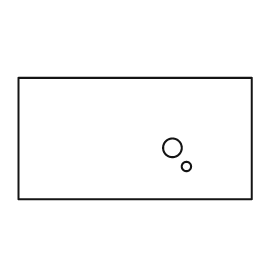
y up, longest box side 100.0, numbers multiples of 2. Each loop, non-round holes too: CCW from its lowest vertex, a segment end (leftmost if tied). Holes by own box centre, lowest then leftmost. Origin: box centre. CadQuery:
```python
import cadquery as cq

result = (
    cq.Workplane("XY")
    .moveTo(-50.0, -26.0)
    .lineTo(50.0, -26.0)
    .lineTo(50.0, 26.0)
    .lineTo(-50.0, 26.0)
    .close()
    .moveTo(22.0, -12.0)
    .circle(2.0)
    .moveTo(16.0, -4.0)
    .circle(4.0)
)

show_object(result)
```